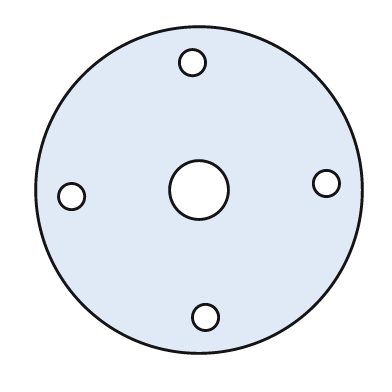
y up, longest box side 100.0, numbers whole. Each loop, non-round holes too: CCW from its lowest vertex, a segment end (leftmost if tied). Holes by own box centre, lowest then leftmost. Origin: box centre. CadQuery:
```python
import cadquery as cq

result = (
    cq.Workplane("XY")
    .moveTo(0.0, 0.0)
    .circle(50.0)
    .moveTo(2.0, -39.0)
    .circle(4.0)
    .moveTo(-39.0, -2.0)
    .circle(4.0)
    .moveTo(0.0, 0.0)
    .circle(9.0)
    .moveTo(39.0, 2.0)
    .circle(4.0)
    .moveTo(-2.0, 39.0)
    .circle(4.0)
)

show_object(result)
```